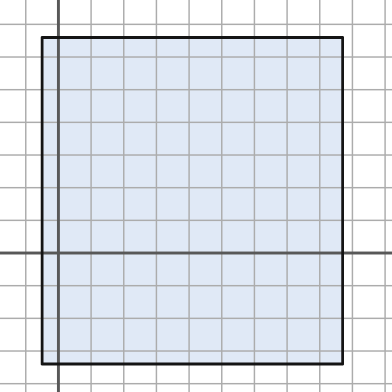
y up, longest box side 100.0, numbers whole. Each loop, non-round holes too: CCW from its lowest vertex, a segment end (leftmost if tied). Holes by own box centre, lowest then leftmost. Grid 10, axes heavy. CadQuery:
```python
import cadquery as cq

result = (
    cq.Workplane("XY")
    .moveTo(-5.0, -34.0)
    .lineTo(87.0, -34.0)
    .lineTo(87.0, 66.0)
    .lineTo(-5.0, 66.0)
    .close()
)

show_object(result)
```